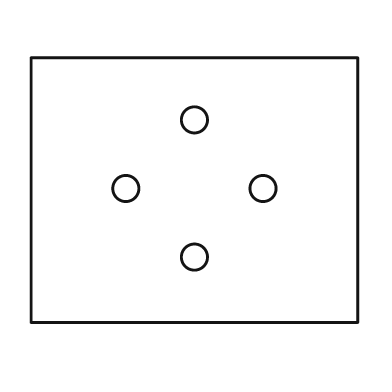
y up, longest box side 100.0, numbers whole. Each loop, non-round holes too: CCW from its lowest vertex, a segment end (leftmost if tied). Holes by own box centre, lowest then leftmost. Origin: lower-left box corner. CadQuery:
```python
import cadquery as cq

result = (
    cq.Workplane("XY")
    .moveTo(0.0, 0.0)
    .lineTo(100.0, 0.0)
    .lineTo(100.0, 81.0)
    .lineTo(0.0, 81.0)
    .close()
    .moveTo(50.0, 20.0)
    .circle(4.0)
    .moveTo(29.0, 41.0)
    .circle(4.0)
    .moveTo(71.0, 41.0)
    .circle(4.0)
    .moveTo(50.0, 62.0)
    .circle(4.0)
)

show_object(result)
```